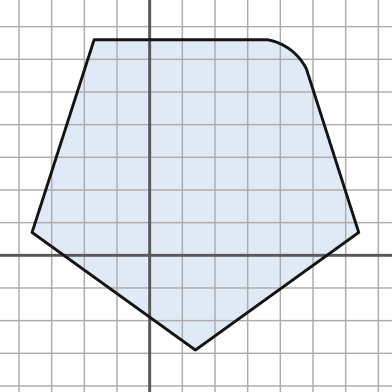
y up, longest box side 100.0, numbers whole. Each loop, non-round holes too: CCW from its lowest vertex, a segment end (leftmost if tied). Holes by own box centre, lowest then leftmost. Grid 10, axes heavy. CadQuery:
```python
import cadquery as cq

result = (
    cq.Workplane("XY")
    .moveTo(14.0, -29.0)
    .lineTo(64.0, 7.0)
    .lineTo(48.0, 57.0)
    .threePointArc((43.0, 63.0), (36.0, 66.0))
    .lineTo(-17.0, 66.0)
    .lineTo(-36.0, 7.0)
    .close()
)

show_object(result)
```